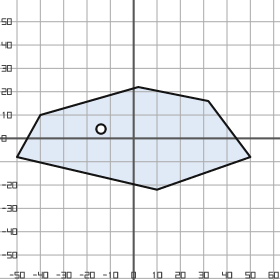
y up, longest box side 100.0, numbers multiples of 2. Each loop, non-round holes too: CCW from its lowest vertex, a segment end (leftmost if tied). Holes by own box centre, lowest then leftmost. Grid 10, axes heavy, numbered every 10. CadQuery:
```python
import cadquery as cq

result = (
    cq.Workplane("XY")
    .moveTo(10.0, -22.0)
    .lineTo(50.0, -8.0)
    .lineTo(32.0, 16.0)
    .lineTo(2.0, 22.0)
    .lineTo(-40.0, 10.0)
    .lineTo(-50.0, -8.0)
    .close()
    .moveTo(-14.0, 4.0)
    .circle(2.0)
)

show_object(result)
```